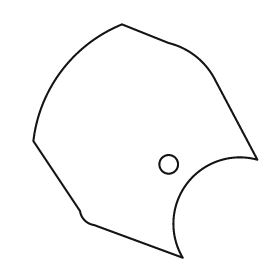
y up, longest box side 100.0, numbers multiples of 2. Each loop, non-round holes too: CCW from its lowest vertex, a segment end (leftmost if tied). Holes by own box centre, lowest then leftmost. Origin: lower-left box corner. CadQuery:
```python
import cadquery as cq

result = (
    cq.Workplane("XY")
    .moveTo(64.0, 0.0)
    .threePointArc((66.0, 32.0), (96.0, 42.0))
    .lineTo(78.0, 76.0)
    .threePointArc((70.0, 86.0), (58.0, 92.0))
    .lineTo(38.0, 100.0)
    .threePointArc((12.0, 80.0), (0.0, 50.0))
    .lineTo(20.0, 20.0)
    .threePointArc((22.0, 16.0), (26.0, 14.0))
    .close()
    .moveTo(58.0, 40.0)
    .circle(4.0)
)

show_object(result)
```